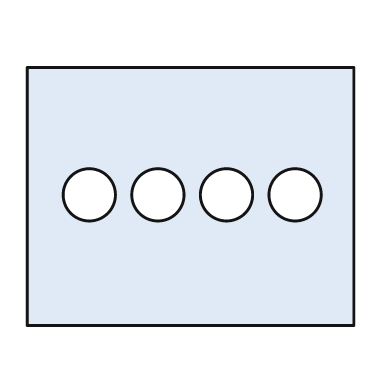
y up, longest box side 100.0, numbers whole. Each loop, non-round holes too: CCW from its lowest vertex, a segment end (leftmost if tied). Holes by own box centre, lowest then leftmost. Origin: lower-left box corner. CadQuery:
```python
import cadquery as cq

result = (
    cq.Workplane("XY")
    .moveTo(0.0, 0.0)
    .lineTo(100.0, 0.0)
    .lineTo(100.0, 79.0)
    .lineTo(0.0, 79.0)
    .close()
    .moveTo(19.0, 40.0)
    .circle(8.0)
    .moveTo(40.0, 40.0)
    .circle(8.0)
    .moveTo(61.0, 40.0)
    .circle(8.0)
    .moveTo(82.0, 40.0)
    .circle(8.0)
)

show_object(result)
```